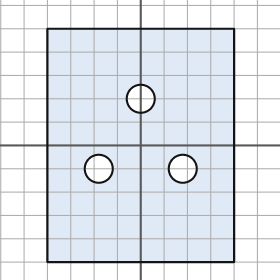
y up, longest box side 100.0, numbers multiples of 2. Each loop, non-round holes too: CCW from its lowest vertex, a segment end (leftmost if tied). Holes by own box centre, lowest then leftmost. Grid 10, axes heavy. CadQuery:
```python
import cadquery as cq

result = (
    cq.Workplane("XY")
    .moveTo(-40.0, -50.0)
    .lineTo(40.0, -50.0)
    .lineTo(40.0, 50.0)
    .lineTo(-40.0, 50.0)
    .close()
    .moveTo(-18.0, -10.0)
    .circle(6.0)
    .moveTo(18.0, -10.0)
    .circle(6.0)
    .moveTo(0.0, 20.0)
    .circle(6.0)
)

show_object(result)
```